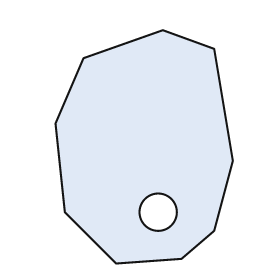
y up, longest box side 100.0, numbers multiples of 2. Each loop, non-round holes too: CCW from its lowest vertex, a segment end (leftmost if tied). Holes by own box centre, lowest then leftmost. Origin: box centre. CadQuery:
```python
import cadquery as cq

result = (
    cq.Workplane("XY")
    .moveTo(-12.0, -50.0)
    .lineTo(16.0, -48.0)
    .lineTo(30.0, -36.0)
    .lineTo(38.0, -6.0)
    .lineTo(30.0, 42.0)
    .lineTo(8.0, 50.0)
    .lineTo(-26.0, 38.0)
    .lineTo(-38.0, 10.0)
    .lineTo(-34.0, -28.0)
    .close()
    .moveTo(6.0, -28.0)
    .circle(8.0)
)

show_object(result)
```